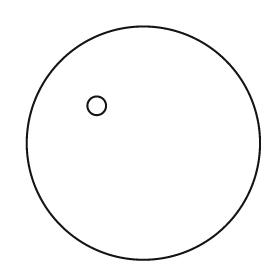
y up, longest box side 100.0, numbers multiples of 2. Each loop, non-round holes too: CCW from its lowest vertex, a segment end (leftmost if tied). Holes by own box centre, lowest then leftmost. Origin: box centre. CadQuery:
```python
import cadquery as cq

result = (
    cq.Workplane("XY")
    .moveTo(0.0, 0.0)
    .circle(50.0)
    .moveTo(-20.0, 16.0)
    .circle(4.0)
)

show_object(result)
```